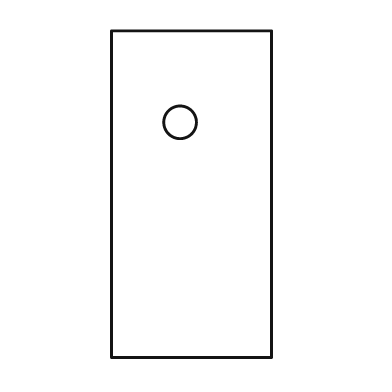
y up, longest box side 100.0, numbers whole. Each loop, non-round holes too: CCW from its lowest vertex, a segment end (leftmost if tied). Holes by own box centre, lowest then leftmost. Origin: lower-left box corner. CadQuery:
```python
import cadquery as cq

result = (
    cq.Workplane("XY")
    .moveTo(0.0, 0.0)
    .lineTo(49.0, 0.0)
    .lineTo(49.0, 100.0)
    .lineTo(0.0, 100.0)
    .close()
    .moveTo(21.0, 72.0)
    .circle(5.0)
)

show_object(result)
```